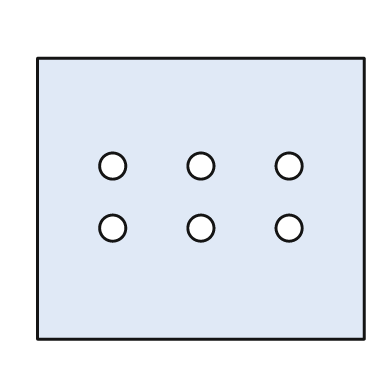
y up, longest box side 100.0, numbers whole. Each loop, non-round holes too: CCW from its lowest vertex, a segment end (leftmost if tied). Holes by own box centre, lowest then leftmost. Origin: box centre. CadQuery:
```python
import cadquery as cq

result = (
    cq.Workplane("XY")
    .moveTo(-50.0, -43.0)
    .lineTo(50.0, -43.0)
    .lineTo(50.0, 43.0)
    .lineTo(-50.0, 43.0)
    .close()
    .moveTo(-27.0, -9.0)
    .circle(4.0)
    .moveTo(0.0, -9.0)
    .circle(4.0)
    .moveTo(27.0, -9.0)
    .circle(4.0)
    .moveTo(-27.0, 10.0)
    .circle(4.0)
    .moveTo(0.0, 10.0)
    .circle(4.0)
    .moveTo(27.0, 10.0)
    .circle(4.0)
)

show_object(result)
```